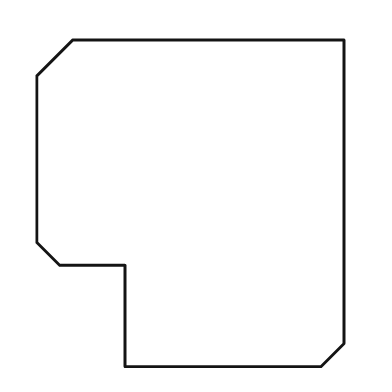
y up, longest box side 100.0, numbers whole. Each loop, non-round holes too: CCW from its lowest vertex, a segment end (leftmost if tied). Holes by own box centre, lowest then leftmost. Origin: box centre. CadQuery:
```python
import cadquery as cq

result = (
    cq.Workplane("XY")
    .moveTo(-20.0, -50.0)
    .lineTo(40.0, -50.0)
    .lineTo(47.0, -43.0)
    .lineTo(47.0, 50.0)
    .lineTo(-36.0, 50.0)
    .lineTo(-47.0, 39.0)
    .lineTo(-47.0, -12.0)
    .lineTo(-40.0, -19.0)
    .lineTo(-20.0, -19.0)
    .close()
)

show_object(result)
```